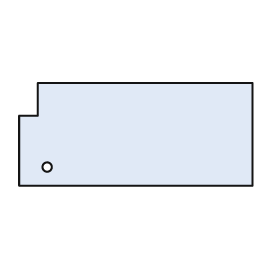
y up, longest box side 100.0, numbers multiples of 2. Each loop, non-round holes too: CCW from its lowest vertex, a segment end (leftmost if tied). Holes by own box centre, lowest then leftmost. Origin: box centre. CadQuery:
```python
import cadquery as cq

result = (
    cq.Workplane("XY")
    .moveTo(-50.0, -22.0)
    .lineTo(50.0, -22.0)
    .lineTo(50.0, 22.0)
    .lineTo(-42.0, 22.0)
    .lineTo(-42.0, 8.0)
    .lineTo(-50.0, 8.0)
    .close()
    .moveTo(-38.0, -14.0)
    .circle(2.0)
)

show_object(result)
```